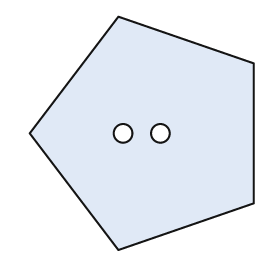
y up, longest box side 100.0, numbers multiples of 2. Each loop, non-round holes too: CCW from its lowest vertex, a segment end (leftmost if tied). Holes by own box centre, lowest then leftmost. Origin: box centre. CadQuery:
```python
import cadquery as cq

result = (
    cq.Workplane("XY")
    .moveTo(-10.0, -50.0)
    .lineTo(48.0, -30.0)
    .lineTo(48.0, 30.0)
    .lineTo(-10.0, 50.0)
    .lineTo(-48.0, 0.0)
    .close()
    .moveTo(-8.0, 0.0)
    .circle(4.0)
    .moveTo(8.0, 0.0)
    .circle(4.0)
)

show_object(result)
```